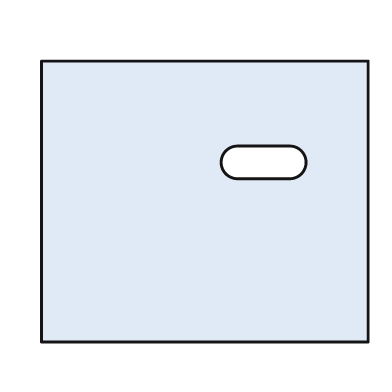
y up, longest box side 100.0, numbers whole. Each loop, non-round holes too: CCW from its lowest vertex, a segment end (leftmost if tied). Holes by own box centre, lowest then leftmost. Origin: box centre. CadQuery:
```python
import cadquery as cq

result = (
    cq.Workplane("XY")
    .moveTo(-50.0, -43.0)
    .lineTo(50.0, -43.0)
    .lineTo(50.0, 43.0)
    .lineTo(-50.0, 43.0)
    .close()
    .moveTo(10.0, 7.0)
    .lineTo(26.0, 7.0)
    .threePointArc((31.0, 12.0), (26.0, 17.0))
    .lineTo(10.0, 17.0)
    .threePointArc((5.0, 12.0), (10.0, 7.0))
    .close()
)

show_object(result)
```